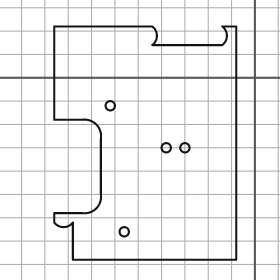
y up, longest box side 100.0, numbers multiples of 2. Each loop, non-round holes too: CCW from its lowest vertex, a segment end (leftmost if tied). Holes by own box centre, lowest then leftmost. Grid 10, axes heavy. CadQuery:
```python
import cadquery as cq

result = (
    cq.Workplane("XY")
    .moveTo(-78.0, -78.0)
    .lineTo(-8.0, -78.0)
    .lineTo(-8.0, 22.0)
    .lineTo(-14.0, 22.0)
    .threePointArc((-12.0, 18.0), (-14.0, 14.0))
    .lineTo(-44.0, 14.0)
    .threePointArc((-42.0, 18.0), (-44.0, 22.0))
    .lineTo(-86.0, 22.0)
    .lineTo(-86.0, -18.0)
    .lineTo(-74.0, -18.0)
    .threePointArc((-68.0, -20.0), (-66.0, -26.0))
    .lineTo(-66.0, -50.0)
    .threePointArc((-68.0, -56.0), (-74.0, -58.0))
    .lineTo(-86.0, -58.0)
    .lineTo(-86.0, -62.0)
    .threePointArc((-82.0, -64.0), (-78.0, -62.0))
    .close()
    .moveTo(-56.0, -66.0)
    .circle(2.0)
    .moveTo(-38.0, -30.0)
    .circle(2.0)
    .moveTo(-30.0, -30.0)
    .circle(2.0)
    .moveTo(-62.0, -12.0)
    .circle(2.0)
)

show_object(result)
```